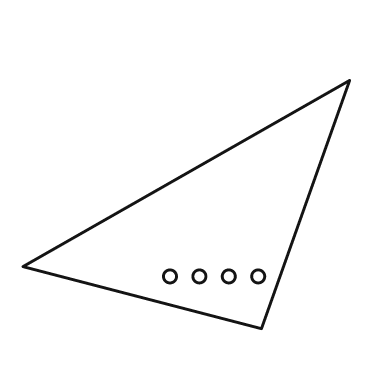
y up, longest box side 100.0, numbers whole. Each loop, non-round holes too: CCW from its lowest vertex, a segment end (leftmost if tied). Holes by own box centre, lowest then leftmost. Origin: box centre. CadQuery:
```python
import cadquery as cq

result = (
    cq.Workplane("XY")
    .moveTo(23.0, -38.0)
    .lineTo(50.0, 38.0)
    .lineTo(-50.0, -19.0)
    .close()
    .moveTo(-5.0, -22.0)
    .circle(2.0)
    .moveTo(4.0, -22.0)
    .circle(2.0)
    .moveTo(13.0, -22.0)
    .circle(2.0)
    .moveTo(22.0, -22.0)
    .circle(2.0)
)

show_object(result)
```